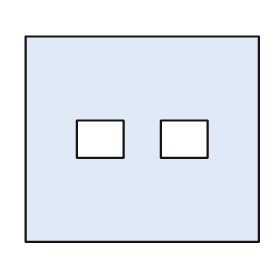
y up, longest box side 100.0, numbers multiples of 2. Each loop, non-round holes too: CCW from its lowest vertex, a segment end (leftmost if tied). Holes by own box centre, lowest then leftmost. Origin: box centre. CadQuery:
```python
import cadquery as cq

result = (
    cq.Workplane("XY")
    .moveTo(-50.0, -44.0)
    .lineTo(50.0, -44.0)
    .lineTo(50.0, 44.0)
    .lineTo(-50.0, 44.0)
    .close()
    .moveTo(-28.0, -8.0)
    .lineTo(-8.0, -8.0)
    .lineTo(-8.0, 8.0)
    .lineTo(-28.0, 8.0)
    .close()
    .moveTo(8.0, -8.0)
    .lineTo(28.0, -8.0)
    .lineTo(28.0, 8.0)
    .lineTo(8.0, 8.0)
    .close()
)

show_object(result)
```